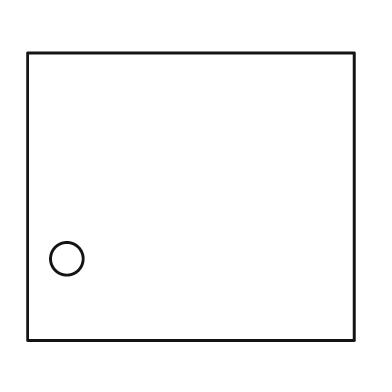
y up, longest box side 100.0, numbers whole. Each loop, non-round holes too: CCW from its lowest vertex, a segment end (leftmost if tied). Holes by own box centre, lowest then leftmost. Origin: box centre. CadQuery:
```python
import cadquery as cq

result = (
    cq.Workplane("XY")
    .moveTo(-50.0, -44.0)
    .lineTo(50.0, -44.0)
    .lineTo(50.0, 44.0)
    .lineTo(-50.0, 44.0)
    .close()
    .moveTo(-38.0, -19.0)
    .circle(5.0)
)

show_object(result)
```